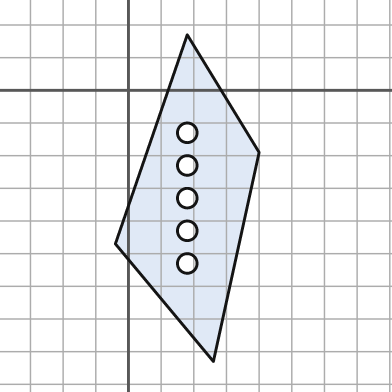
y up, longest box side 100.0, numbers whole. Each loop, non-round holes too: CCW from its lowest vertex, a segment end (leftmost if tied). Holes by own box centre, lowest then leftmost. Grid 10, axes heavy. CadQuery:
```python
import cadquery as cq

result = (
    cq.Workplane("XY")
    .moveTo(26.0, -83.0)
    .lineTo(40.0, -19.0)
    .lineTo(18.0, 17.0)
    .lineTo(-4.0, -47.0)
    .close()
    .moveTo(18.0, -53.0)
    .circle(3.0)
    .moveTo(18.0, -43.0)
    .circle(3.0)
    .moveTo(18.0, -33.0)
    .circle(3.0)
    .moveTo(18.0, -23.0)
    .circle(3.0)
    .moveTo(18.0, -13.0)
    .circle(3.0)
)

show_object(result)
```